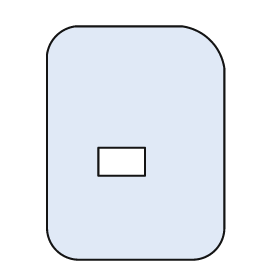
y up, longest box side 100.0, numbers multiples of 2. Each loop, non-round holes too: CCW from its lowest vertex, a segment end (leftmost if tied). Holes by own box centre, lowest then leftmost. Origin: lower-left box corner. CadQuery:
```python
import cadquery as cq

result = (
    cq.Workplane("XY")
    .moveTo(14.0, 0.0)
    .lineTo(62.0, 0.0)
    .threePointArc((72.0, 4.0), (76.0, 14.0))
    .lineTo(76.0, 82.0)
    .threePointArc((70.0, 94.0), (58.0, 100.0))
    .lineTo(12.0, 100.0)
    .threePointArc((4.0, 96.0), (0.0, 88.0))
    .lineTo(0.0, 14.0)
    .threePointArc((4.0, 4.0), (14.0, 0.0))
    .close()
    .moveTo(22.0, 36.0)
    .lineTo(42.0, 36.0)
    .lineTo(42.0, 48.0)
    .lineTo(22.0, 48.0)
    .close()
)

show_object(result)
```